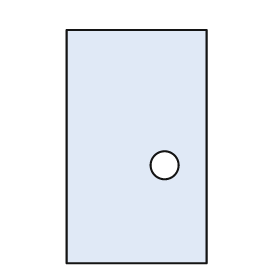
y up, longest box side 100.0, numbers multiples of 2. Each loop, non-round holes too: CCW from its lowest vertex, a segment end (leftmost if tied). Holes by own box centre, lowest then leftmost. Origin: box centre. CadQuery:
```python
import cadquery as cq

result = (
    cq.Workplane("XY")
    .moveTo(-30.0, -50.0)
    .lineTo(30.0, -50.0)
    .lineTo(30.0, 50.0)
    .lineTo(-30.0, 50.0)
    .close()
    .moveTo(12.0, -8.0)
    .circle(6.0)
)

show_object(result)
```